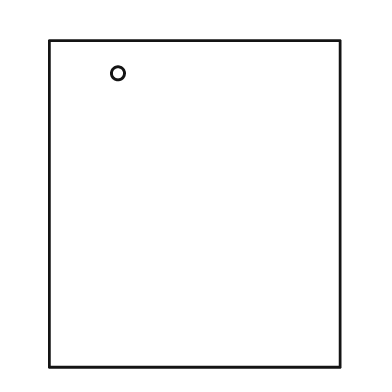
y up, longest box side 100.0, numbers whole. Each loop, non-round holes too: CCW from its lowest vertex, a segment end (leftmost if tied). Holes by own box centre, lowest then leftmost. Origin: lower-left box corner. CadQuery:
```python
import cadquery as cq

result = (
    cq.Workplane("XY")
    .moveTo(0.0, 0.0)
    .lineTo(89.0, 0.0)
    .lineTo(89.0, 100.0)
    .lineTo(0.0, 100.0)
    .close()
    .moveTo(21.0, 90.0)
    .circle(2.0)
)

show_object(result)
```